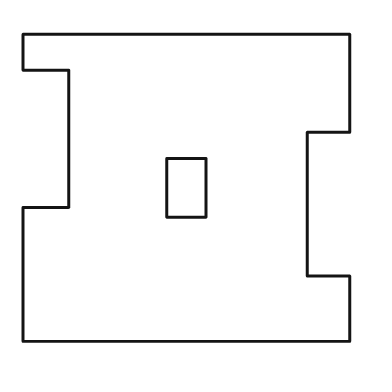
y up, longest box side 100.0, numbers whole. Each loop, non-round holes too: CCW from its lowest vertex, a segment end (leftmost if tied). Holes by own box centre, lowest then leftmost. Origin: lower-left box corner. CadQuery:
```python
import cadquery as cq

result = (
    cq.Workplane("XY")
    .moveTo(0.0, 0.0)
    .lineTo(100.0, 0.0)
    .lineTo(100.0, 20.0)
    .lineTo(87.0, 20.0)
    .lineTo(87.0, 64.0)
    .lineTo(100.0, 64.0)
    .lineTo(100.0, 94.0)
    .lineTo(0.0, 94.0)
    .lineTo(0.0, 83.0)
    .lineTo(14.0, 83.0)
    .lineTo(14.0, 41.0)
    .lineTo(0.0, 41.0)
    .close()
    .moveTo(44.0, 38.0)
    .lineTo(56.0, 38.0)
    .lineTo(56.0, 56.0)
    .lineTo(44.0, 56.0)
    .close()
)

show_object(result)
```